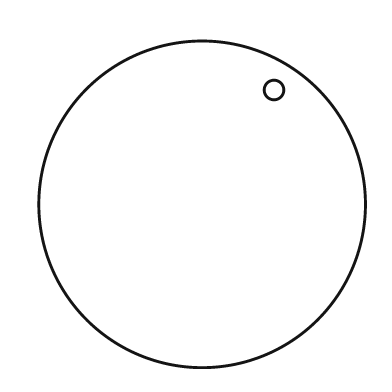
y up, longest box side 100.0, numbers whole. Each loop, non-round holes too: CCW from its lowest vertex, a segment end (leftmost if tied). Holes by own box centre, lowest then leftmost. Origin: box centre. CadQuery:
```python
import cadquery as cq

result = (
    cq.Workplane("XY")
    .moveTo(0.0, 0.0)
    .circle(50.0)
    .moveTo(22.0, 35.0)
    .circle(3.0)
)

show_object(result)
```